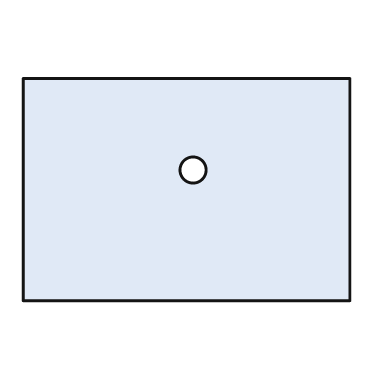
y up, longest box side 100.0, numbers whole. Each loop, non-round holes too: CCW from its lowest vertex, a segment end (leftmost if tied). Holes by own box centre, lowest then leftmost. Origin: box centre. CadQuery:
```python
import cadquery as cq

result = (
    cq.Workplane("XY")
    .moveTo(-50.0, -34.0)
    .lineTo(50.0, -34.0)
    .lineTo(50.0, 34.0)
    .lineTo(-50.0, 34.0)
    .close()
    .moveTo(2.0, 6.0)
    .circle(4.0)
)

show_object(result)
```